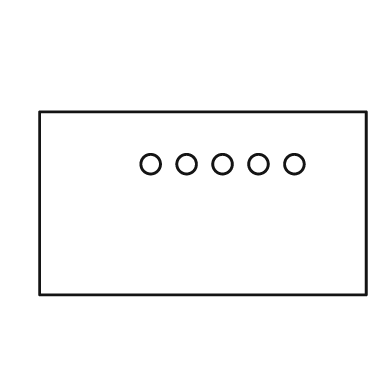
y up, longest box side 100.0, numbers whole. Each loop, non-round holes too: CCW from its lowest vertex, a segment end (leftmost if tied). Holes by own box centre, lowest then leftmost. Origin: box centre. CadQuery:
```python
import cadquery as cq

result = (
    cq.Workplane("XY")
    .moveTo(-50.0, -28.0)
    .lineTo(50.0, -28.0)
    .lineTo(50.0, 28.0)
    .lineTo(-50.0, 28.0)
    .close()
    .moveTo(-16.0, 12.0)
    .circle(3.0)
    .moveTo(-5.0, 12.0)
    .circle(3.0)
    .moveTo(6.0, 12.0)
    .circle(3.0)
    .moveTo(17.0, 12.0)
    .circle(3.0)
    .moveTo(28.0, 12.0)
    .circle(3.0)
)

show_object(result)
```